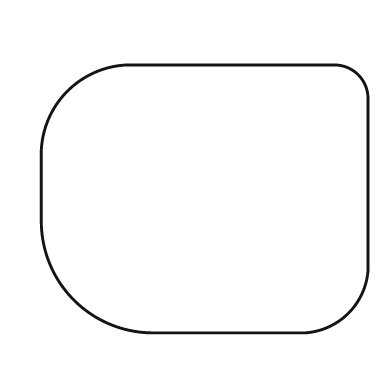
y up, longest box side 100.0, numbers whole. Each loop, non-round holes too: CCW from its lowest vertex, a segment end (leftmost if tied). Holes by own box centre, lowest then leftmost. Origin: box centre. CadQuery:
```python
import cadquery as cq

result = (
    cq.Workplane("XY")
    .moveTo(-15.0, -41.0)
    .lineTo(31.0, -41.0)
    .threePointArc((44.0, -35.0), (50.0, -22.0))
    .lineTo(50.0, 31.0)
    .threePointArc((47.0, 38.0), (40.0, 41.0))
    .lineTo(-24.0, 41.0)
    .threePointArc((-42.0, 33.0), (-50.0, 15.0))
    .lineTo(-50.0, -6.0)
    .threePointArc((-40.0, -31.0), (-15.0, -41.0))
    .close()
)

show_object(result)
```